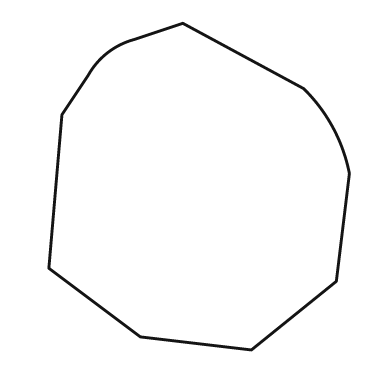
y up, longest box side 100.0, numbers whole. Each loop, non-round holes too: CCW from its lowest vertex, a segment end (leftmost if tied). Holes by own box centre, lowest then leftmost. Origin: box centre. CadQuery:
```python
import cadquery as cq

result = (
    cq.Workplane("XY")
    .moveTo(16.0, -50.0)
    .lineTo(42.0, -29.0)
    .lineTo(46.0, 4.0)
    .threePointArc((41.0, 18.0), (32.0, 30.0))
    .lineTo(-5.0, 50.0)
    .lineTo(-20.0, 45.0)
    .threePointArc((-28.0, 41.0), (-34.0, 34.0))
    .lineTo(-42.0, 22.0)
    .lineTo(-46.0, -25.0)
    .lineTo(-18.0, -46.0)
    .close()
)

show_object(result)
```